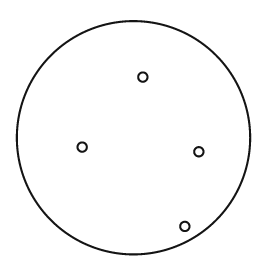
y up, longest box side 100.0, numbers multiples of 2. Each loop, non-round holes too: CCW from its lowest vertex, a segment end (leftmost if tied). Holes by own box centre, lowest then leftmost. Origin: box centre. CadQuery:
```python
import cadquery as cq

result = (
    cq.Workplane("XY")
    .moveTo(0.0, 0.0)
    .circle(50.0)
    .moveTo(22.0, -38.0)
    .circle(2.0)
    .moveTo(28.0, -6.0)
    .circle(2.0)
    .moveTo(-22.0, -4.0)
    .circle(2.0)
    .moveTo(4.0, 26.0)
    .circle(2.0)
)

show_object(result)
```